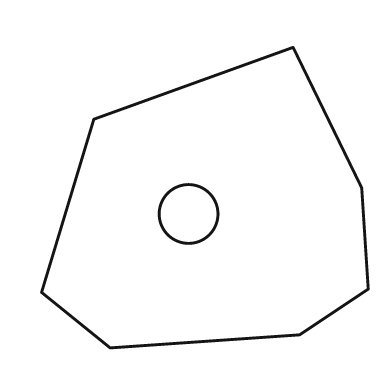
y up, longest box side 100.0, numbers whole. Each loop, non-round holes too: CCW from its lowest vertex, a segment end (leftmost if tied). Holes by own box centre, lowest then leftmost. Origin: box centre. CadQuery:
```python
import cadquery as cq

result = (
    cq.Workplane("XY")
    .moveTo(-29.0, -46.0)
    .lineTo(29.0, -42.0)
    .lineTo(50.0, -28.0)
    .lineTo(48.0, 3.0)
    .lineTo(27.0, 46.0)
    .lineTo(-34.0, 24.0)
    .lineTo(-50.0, -29.0)
    .close()
    .moveTo(-5.0, -5.0)
    .circle(9.0)
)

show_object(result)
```